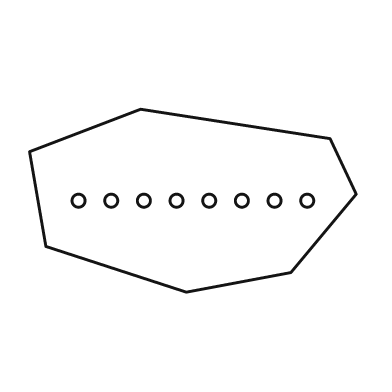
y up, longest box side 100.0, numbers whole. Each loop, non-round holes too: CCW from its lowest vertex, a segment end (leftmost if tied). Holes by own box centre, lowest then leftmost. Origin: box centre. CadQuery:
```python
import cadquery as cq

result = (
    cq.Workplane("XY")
    .moveTo(-2.0, -28.0)
    .lineTo(30.0, -22.0)
    .lineTo(50.0, 2.0)
    .lineTo(42.0, 19.0)
    .lineTo(-16.0, 28.0)
    .lineTo(-50.0, 15.0)
    .lineTo(-45.0, -14.0)
    .close()
    .moveTo(-35.0, 0.0)
    .circle(2.0)
    .moveTo(-25.0, 0.0)
    .circle(2.0)
    .moveTo(-15.0, 0.0)
    .circle(2.0)
    .moveTo(-5.0, 0.0)
    .circle(2.0)
    .moveTo(5.0, 0.0)
    .circle(2.0)
    .moveTo(15.0, 0.0)
    .circle(2.0)
    .moveTo(25.0, 0.0)
    .circle(2.0)
    .moveTo(35.0, 0.0)
    .circle(2.0)
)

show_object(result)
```